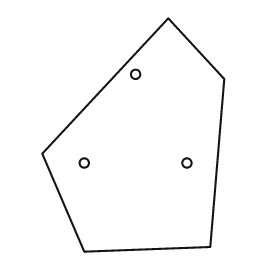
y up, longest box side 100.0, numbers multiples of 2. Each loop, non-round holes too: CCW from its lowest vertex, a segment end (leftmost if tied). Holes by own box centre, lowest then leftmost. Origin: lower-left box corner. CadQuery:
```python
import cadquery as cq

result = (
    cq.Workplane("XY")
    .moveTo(18.0, 0.0)
    .lineTo(72.0, 2.0)
    .lineTo(78.0, 74.0)
    .lineTo(54.0, 100.0)
    .lineTo(0.0, 42.0)
    .close()
    .moveTo(18.0, 38.0)
    .circle(2.0)
    .moveTo(62.0, 38.0)
    .circle(2.0)
    .moveTo(40.0, 76.0)
    .circle(2.0)
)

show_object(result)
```